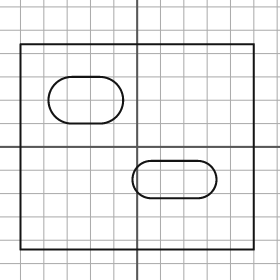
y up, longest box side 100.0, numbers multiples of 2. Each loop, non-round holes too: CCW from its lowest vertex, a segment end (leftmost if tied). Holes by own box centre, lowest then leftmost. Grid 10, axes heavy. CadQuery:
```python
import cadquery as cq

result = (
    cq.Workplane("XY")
    .moveTo(-50.0, -44.0)
    .lineTo(50.0, -44.0)
    .lineTo(50.0, 44.0)
    .lineTo(-50.0, 44.0)
    .close()
    .moveTo(6.0, -22.0)
    .lineTo(26.0, -22.0)
    .threePointArc((34.0, -14.0), (26.0, -6.0))
    .lineTo(6.0, -6.0)
    .threePointArc((-2.0, -14.0), (6.0, -22.0))
    .close()
    .moveTo(-28.0, 10.0)
    .lineTo(-16.0, 10.0)
    .threePointArc((-6.0, 20.0), (-16.0, 30.0))
    .lineTo(-28.0, 30.0)
    .threePointArc((-38.0, 20.0), (-28.0, 10.0))
    .close()
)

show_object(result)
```